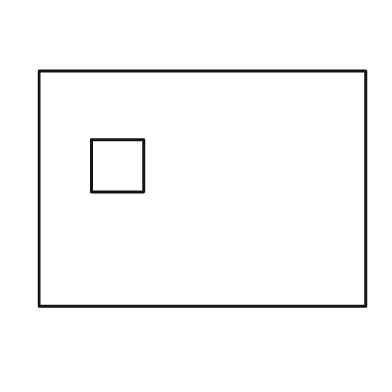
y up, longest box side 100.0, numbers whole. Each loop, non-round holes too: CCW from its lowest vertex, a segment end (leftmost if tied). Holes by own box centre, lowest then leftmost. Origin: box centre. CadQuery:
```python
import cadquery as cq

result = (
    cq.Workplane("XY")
    .moveTo(-50.0, -36.0)
    .lineTo(50.0, -36.0)
    .lineTo(50.0, 36.0)
    .lineTo(-50.0, 36.0)
    .close()
    .moveTo(-34.0, -1.0)
    .lineTo(-18.0, -1.0)
    .lineTo(-18.0, 15.0)
    .lineTo(-34.0, 15.0)
    .close()
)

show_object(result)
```